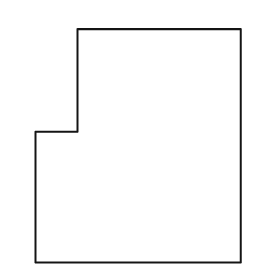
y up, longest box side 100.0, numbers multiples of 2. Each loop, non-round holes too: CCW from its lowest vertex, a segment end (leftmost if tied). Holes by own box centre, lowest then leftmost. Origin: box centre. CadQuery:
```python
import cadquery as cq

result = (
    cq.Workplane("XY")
    .moveTo(-44.0, -50.0)
    .lineTo(44.0, -50.0)
    .lineTo(44.0, 50.0)
    .lineTo(-26.0, 50.0)
    .lineTo(-26.0, 6.0)
    .lineTo(-44.0, 6.0)
    .close()
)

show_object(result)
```